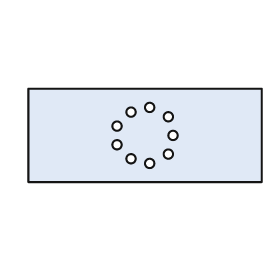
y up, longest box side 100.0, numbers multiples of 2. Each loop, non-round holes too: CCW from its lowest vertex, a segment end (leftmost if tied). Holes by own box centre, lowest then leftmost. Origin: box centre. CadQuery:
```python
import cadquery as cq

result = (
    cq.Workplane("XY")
    .moveTo(-50.0, -20.0)
    .lineTo(50.0, -20.0)
    .lineTo(50.0, 20.0)
    .lineTo(-50.0, 20.0)
    .close()
    .moveTo(2.0, -12.0)
    .circle(2.0)
    .moveTo(-6.0, -10.0)
    .circle(2.0)
    .moveTo(10.0, -8.0)
    .circle(2.0)
    .moveTo(-12.0, -4.0)
    .circle(2.0)
    .moveTo(12.0, 0.0)
    .circle(2.0)
    .moveTo(-12.0, 4.0)
    .circle(2.0)
    .moveTo(10.0, 8.0)
    .circle(2.0)
    .moveTo(-6.0, 10.0)
    .circle(2.0)
    .moveTo(2.0, 12.0)
    .circle(2.0)
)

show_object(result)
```